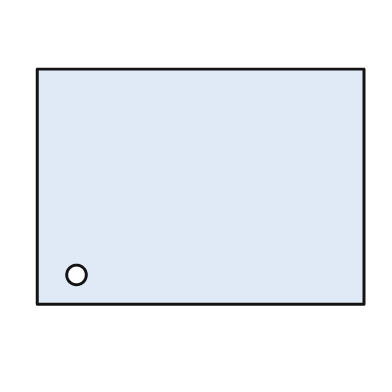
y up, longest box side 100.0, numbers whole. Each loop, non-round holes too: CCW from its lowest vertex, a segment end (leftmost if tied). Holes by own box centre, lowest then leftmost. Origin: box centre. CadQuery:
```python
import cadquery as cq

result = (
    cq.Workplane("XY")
    .moveTo(-50.0, -36.0)
    .lineTo(50.0, -36.0)
    .lineTo(50.0, 36.0)
    .lineTo(-50.0, 36.0)
    .close()
    .moveTo(-38.0, -27.0)
    .circle(3.0)
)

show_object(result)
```